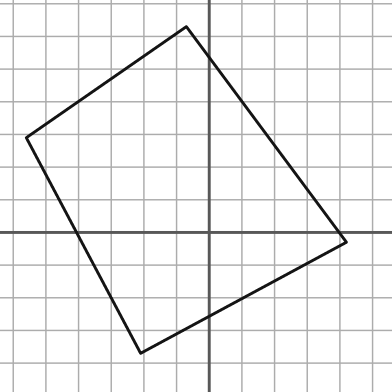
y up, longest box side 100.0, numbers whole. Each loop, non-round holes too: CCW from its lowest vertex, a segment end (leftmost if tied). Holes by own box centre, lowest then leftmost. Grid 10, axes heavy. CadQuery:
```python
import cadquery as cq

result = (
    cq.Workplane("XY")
    .moveTo(-21.0, -37.0)
    .lineTo(42.0, -3.0)
    .lineTo(-7.0, 63.0)
    .lineTo(-56.0, 29.0)
    .close()
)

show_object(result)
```